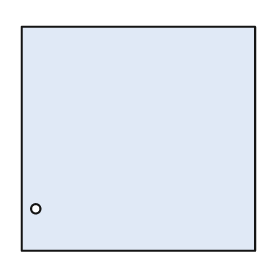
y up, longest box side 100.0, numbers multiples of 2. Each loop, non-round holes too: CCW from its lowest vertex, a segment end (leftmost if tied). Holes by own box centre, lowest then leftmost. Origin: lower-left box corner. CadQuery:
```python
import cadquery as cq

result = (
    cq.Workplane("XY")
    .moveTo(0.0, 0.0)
    .lineTo(100.0, 0.0)
    .lineTo(100.0, 96.0)
    .lineTo(0.0, 96.0)
    .close()
    .moveTo(6.0, 18.0)
    .circle(2.0)
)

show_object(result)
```